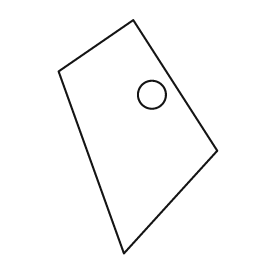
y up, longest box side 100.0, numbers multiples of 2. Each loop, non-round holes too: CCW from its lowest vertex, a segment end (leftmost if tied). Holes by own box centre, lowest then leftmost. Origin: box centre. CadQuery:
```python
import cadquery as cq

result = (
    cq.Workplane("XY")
    .moveTo(-6.0, -50.0)
    .lineTo(34.0, -6.0)
    .lineTo(-2.0, 50.0)
    .lineTo(-34.0, 28.0)
    .close()
    .moveTo(6.0, 18.0)
    .circle(6.0)
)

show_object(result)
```